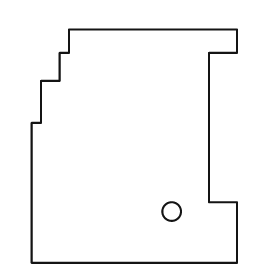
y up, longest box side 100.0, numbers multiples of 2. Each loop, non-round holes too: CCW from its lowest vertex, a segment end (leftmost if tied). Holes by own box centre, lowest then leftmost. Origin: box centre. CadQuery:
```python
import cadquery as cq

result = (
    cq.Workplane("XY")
    .moveTo(-44.0, -50.0)
    .lineTo(44.0, -50.0)
    .lineTo(44.0, -24.0)
    .lineTo(32.0, -24.0)
    .lineTo(32.0, 40.0)
    .lineTo(44.0, 40.0)
    .lineTo(44.0, 50.0)
    .lineTo(-28.0, 50.0)
    .lineTo(-28.0, 40.0)
    .lineTo(-32.0, 40.0)
    .lineTo(-32.0, 28.0)
    .lineTo(-40.0, 28.0)
    .lineTo(-40.0, 10.0)
    .lineTo(-44.0, 10.0)
    .close()
    .moveTo(16.0, -28.0)
    .circle(4.0)
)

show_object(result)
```